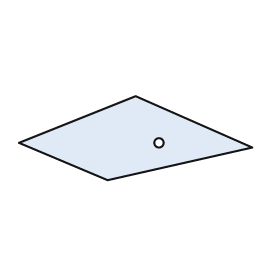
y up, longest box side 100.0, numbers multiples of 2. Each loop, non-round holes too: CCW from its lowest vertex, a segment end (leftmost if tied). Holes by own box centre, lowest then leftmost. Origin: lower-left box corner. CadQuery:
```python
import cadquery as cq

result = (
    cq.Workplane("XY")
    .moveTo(38.0, 0.0)
    .lineTo(100.0, 14.0)
    .lineTo(50.0, 36.0)
    .lineTo(0.0, 16.0)
    .close()
    .moveTo(60.0, 16.0)
    .circle(2.0)
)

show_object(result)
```